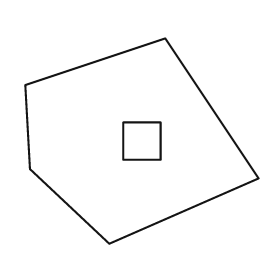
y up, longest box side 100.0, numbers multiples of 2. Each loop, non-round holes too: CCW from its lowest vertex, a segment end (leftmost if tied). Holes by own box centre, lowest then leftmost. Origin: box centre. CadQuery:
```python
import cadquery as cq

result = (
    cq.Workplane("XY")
    .moveTo(-14.0, -44.0)
    .lineTo(50.0, -16.0)
    .lineTo(10.0, 44.0)
    .lineTo(-50.0, 24.0)
    .lineTo(-48.0, -12.0)
    .close()
    .moveTo(-8.0, -8.0)
    .lineTo(8.0, -8.0)
    .lineTo(8.0, 8.0)
    .lineTo(-8.0, 8.0)
    .close()
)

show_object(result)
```